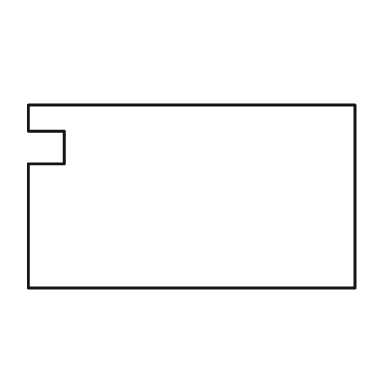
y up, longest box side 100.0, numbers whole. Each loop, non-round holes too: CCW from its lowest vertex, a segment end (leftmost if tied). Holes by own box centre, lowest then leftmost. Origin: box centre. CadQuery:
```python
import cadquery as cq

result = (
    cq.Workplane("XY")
    .moveTo(-50.0, -28.0)
    .lineTo(50.0, -28.0)
    .lineTo(50.0, 28.0)
    .lineTo(-50.0, 28.0)
    .lineTo(-50.0, 20.0)
    .lineTo(-39.0, 20.0)
    .lineTo(-39.0, 10.0)
    .lineTo(-50.0, 10.0)
    .close()
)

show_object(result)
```